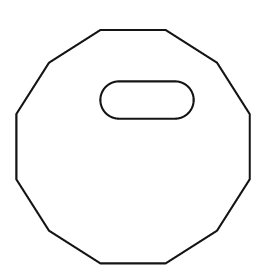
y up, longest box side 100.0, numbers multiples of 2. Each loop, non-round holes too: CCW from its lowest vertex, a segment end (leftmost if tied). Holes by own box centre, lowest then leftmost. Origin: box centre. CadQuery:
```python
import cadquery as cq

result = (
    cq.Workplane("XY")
    .moveTo(-14.0, -50.0)
    .lineTo(14.0, -50.0)
    .lineTo(36.0, -36.0)
    .lineTo(50.0, -14.0)
    .lineTo(50.0, 14.0)
    .lineTo(36.0, 36.0)
    .lineTo(14.0, 50.0)
    .lineTo(-14.0, 50.0)
    .lineTo(-36.0, 36.0)
    .lineTo(-50.0, 14.0)
    .lineTo(-50.0, -14.0)
    .lineTo(-36.0, -36.0)
    .close()
    .moveTo(-6.0, 12.0)
    .lineTo(18.0, 12.0)
    .threePointArc((26.0, 20.0), (18.0, 28.0))
    .lineTo(-6.0, 28.0)
    .threePointArc((-14.0, 20.0), (-6.0, 12.0))
    .close()
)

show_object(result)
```